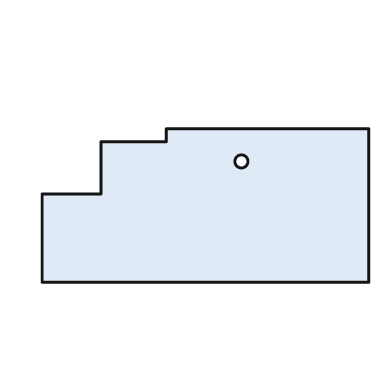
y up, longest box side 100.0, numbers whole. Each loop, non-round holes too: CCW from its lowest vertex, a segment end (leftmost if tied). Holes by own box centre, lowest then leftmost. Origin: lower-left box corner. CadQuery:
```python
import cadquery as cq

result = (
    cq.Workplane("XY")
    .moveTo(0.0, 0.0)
    .lineTo(100.0, 0.0)
    .lineTo(100.0, 47.0)
    .lineTo(38.0, 47.0)
    .lineTo(38.0, 43.0)
    .lineTo(18.0, 43.0)
    .lineTo(18.0, 27.0)
    .lineTo(0.0, 27.0)
    .close()
    .moveTo(61.0, 37.0)
    .circle(2.0)
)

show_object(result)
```